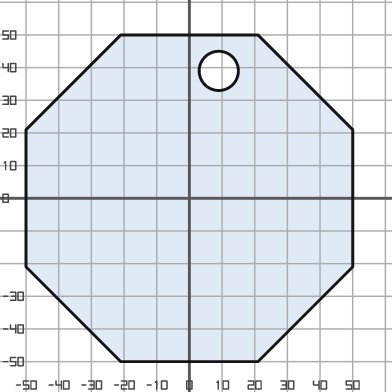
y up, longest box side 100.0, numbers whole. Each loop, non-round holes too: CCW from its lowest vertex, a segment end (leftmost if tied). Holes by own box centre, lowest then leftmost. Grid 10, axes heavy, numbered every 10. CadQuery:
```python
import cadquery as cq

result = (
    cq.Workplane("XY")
    .moveTo(-21.0, -50.0)
    .lineTo(21.0, -50.0)
    .lineTo(50.0, -21.0)
    .lineTo(50.0, 21.0)
    .lineTo(21.0, 50.0)
    .lineTo(-21.0, 50.0)
    .lineTo(-50.0, 21.0)
    .lineTo(-50.0, -21.0)
    .close()
    .moveTo(9.0, 39.0)
    .circle(6.0)
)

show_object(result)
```